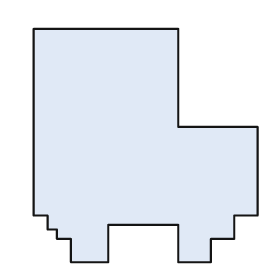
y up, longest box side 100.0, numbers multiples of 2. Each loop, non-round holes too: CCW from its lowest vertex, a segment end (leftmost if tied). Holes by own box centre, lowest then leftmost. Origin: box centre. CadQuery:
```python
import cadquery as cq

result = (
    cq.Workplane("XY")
    .moveTo(-32.0, -50.0)
    .lineTo(-16.0, -50.0)
    .lineTo(-16.0, -34.0)
    .lineTo(14.0, -34.0)
    .lineTo(14.0, -50.0)
    .lineTo(28.0, -50.0)
    .lineTo(28.0, -40.0)
    .lineTo(38.0, -40.0)
    .lineTo(38.0, -30.0)
    .lineTo(48.0, -30.0)
    .lineTo(48.0, 8.0)
    .lineTo(14.0, 8.0)
    .lineTo(14.0, 50.0)
    .lineTo(-48.0, 50.0)
    .lineTo(-48.0, -30.0)
    .lineTo(-42.0, -30.0)
    .lineTo(-42.0, -36.0)
    .lineTo(-38.0, -36.0)
    .lineTo(-38.0, -40.0)
    .lineTo(-32.0, -40.0)
    .close()
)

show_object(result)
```